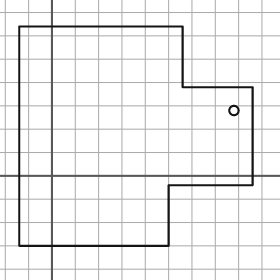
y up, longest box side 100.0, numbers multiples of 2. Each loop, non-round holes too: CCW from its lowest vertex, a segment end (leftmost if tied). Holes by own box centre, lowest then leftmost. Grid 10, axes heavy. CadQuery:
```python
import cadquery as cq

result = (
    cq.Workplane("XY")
    .moveTo(-14.0, -30.0)
    .lineTo(50.0, -30.0)
    .lineTo(50.0, -4.0)
    .lineTo(86.0, -4.0)
    .lineTo(86.0, 38.0)
    .lineTo(56.0, 38.0)
    .lineTo(56.0, 64.0)
    .lineTo(-14.0, 64.0)
    .close()
    .moveTo(78.0, 28.0)
    .circle(2.0)
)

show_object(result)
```